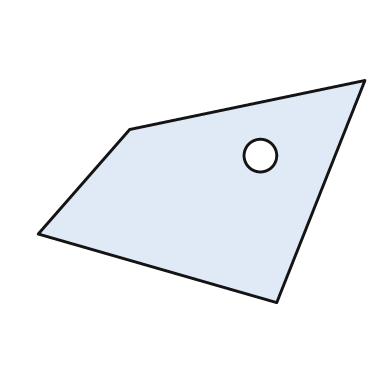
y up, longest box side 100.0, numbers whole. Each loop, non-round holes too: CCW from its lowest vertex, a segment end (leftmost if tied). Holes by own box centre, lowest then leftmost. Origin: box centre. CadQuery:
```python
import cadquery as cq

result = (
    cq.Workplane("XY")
    .moveTo(23.0, -34.0)
    .lineTo(50.0, 34.0)
    .lineTo(-22.0, 19.0)
    .lineTo(-50.0, -13.0)
    .close()
    .moveTo(18.0, 11.0)
    .circle(5.0)
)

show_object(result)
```